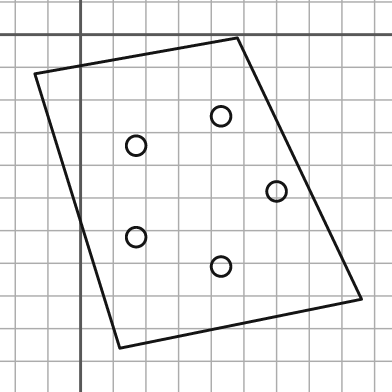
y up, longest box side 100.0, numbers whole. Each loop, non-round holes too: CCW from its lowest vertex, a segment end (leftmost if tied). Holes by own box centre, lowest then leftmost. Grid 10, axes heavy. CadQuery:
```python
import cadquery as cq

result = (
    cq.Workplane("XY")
    .moveTo(12.0, -96.0)
    .lineTo(86.0, -81.0)
    .lineTo(48.0, -1.0)
    .lineTo(-14.0, -12.0)
    .close()
    .moveTo(43.0, -71.0)
    .circle(3.0)
    .moveTo(17.0, -62.0)
    .circle(3.0)
    .moveTo(60.0, -48.0)
    .circle(3.0)
    .moveTo(17.0, -34.0)
    .circle(3.0)
    .moveTo(43.0, -25.0)
    .circle(3.0)
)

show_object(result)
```